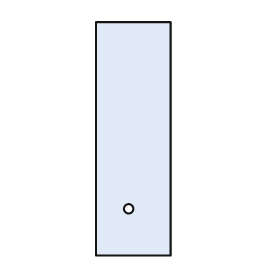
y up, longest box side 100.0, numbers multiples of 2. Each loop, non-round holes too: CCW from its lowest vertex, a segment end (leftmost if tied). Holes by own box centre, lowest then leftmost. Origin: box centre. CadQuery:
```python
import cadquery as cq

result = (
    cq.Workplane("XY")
    .moveTo(-16.0, -50.0)
    .lineTo(16.0, -50.0)
    .lineTo(16.0, 50.0)
    .lineTo(-16.0, 50.0)
    .close()
    .moveTo(-2.0, -30.0)
    .circle(2.0)
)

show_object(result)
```